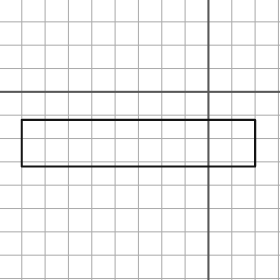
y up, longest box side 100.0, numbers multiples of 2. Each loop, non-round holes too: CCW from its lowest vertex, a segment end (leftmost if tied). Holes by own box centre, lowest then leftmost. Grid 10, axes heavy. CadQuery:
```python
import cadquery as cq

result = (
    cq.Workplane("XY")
    .moveTo(-80.0, -32.0)
    .lineTo(20.0, -32.0)
    .lineTo(20.0, -12.0)
    .lineTo(-80.0, -12.0)
    .close()
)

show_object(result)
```